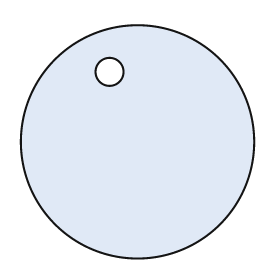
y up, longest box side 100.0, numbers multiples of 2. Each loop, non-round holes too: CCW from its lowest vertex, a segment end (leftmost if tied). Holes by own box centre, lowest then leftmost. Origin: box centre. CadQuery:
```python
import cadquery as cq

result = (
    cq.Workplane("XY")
    .moveTo(0.0, 0.0)
    .circle(50.0)
    .moveTo(-12.0, 30.0)
    .circle(6.0)
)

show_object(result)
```